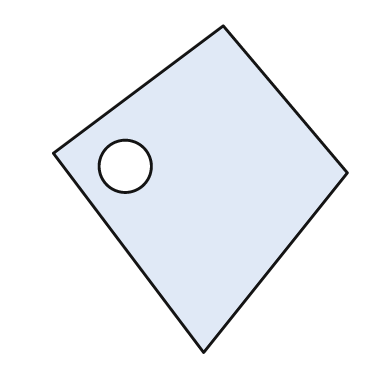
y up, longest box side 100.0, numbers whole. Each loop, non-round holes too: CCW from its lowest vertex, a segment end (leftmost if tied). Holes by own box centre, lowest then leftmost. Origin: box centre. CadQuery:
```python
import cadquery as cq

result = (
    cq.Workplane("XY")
    .moveTo(1.0, -50.0)
    .lineTo(45.0, 5.0)
    .lineTo(7.0, 50.0)
    .lineTo(-45.0, 11.0)
    .close()
    .moveTo(-23.0, 7.0)
    .circle(8.0)
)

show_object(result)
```